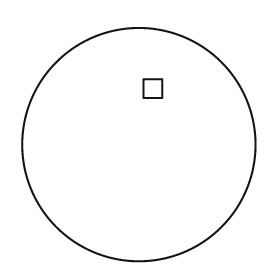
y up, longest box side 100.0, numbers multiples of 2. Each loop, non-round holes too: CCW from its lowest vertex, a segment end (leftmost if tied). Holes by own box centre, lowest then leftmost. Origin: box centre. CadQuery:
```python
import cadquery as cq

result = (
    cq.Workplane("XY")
    .moveTo(0.0, 0.0)
    .circle(50.0)
    .moveTo(2.0, 20.0)
    .lineTo(10.0, 20.0)
    .lineTo(10.0, 28.0)
    .lineTo(2.0, 28.0)
    .close()
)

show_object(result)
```